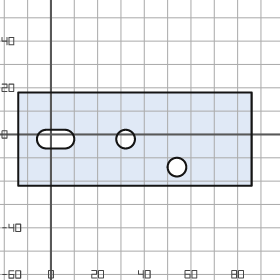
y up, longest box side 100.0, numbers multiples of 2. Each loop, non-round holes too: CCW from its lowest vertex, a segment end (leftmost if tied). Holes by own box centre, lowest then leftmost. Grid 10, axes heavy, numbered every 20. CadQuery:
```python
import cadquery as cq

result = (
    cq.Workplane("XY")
    .moveTo(-14.0, -22.0)
    .lineTo(86.0, -22.0)
    .lineTo(86.0, 18.0)
    .lineTo(-14.0, 18.0)
    .close()
    .moveTo(54.0, -14.0)
    .circle(4.0)
    .moveTo(-2.0, -6.0)
    .lineTo(6.0, -6.0)
    .threePointArc((10.0, -2.0), (6.0, 2.0))
    .lineTo(-2.0, 2.0)
    .threePointArc((-6.0, -2.0), (-2.0, -6.0))
    .close()
    .moveTo(32.0, -2.0)
    .circle(4.0)
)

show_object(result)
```